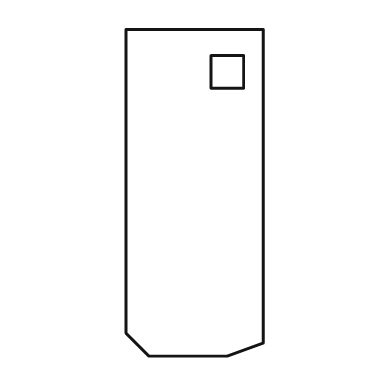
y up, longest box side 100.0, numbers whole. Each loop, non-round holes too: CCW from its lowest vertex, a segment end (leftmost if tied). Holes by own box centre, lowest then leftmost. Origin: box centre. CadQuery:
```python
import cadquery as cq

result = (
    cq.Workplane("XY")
    .moveTo(-14.0, -50.0)
    .lineTo(10.0, -50.0)
    .lineTo(21.0, -46.0)
    .lineTo(21.0, 50.0)
    .lineTo(-21.0, 50.0)
    .lineTo(-21.0, -43.0)
    .close()
    .moveTo(5.0, 32.0)
    .lineTo(15.0, 32.0)
    .lineTo(15.0, 42.0)
    .lineTo(5.0, 42.0)
    .close()
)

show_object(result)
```